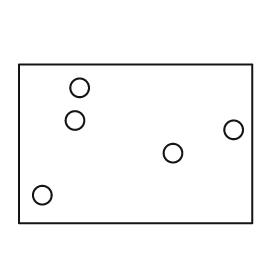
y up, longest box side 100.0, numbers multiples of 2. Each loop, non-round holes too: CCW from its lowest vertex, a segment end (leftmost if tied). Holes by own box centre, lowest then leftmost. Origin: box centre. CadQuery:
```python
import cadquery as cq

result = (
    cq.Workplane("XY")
    .moveTo(-50.0, -34.0)
    .lineTo(50.0, -34.0)
    .lineTo(50.0, 34.0)
    .lineTo(-50.0, 34.0)
    .close()
    .moveTo(-40.0, -22.0)
    .circle(4.0)
    .moveTo(16.0, -4.0)
    .circle(4.0)
    .moveTo(42.0, 6.0)
    .circle(4.0)
    .moveTo(-26.0, 10.0)
    .circle(4.0)
    .moveTo(-24.0, 24.0)
    .circle(4.0)
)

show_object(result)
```